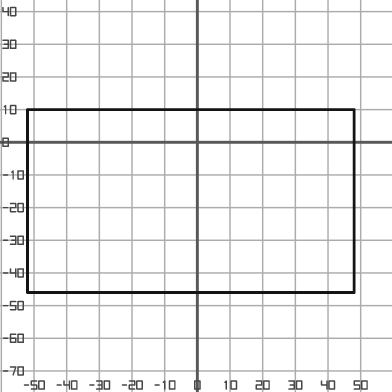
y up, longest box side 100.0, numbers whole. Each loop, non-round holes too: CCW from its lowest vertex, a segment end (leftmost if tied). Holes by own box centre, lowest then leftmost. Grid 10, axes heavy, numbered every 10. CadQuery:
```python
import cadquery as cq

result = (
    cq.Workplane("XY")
    .moveTo(-52.0, -46.0)
    .lineTo(48.0, -46.0)
    .lineTo(48.0, 10.0)
    .lineTo(-52.0, 10.0)
    .close()
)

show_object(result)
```